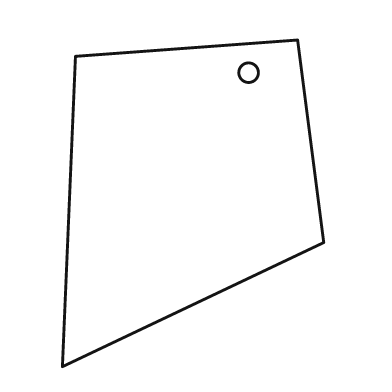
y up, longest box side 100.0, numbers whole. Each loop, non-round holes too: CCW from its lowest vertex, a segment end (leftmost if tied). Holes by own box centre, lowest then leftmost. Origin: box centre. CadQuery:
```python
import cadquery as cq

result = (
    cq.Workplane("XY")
    .moveTo(-40.0, -50.0)
    .lineTo(40.0, -12.0)
    .lineTo(32.0, 50.0)
    .lineTo(-36.0, 45.0)
    .close()
    .moveTo(17.0, 40.0)
    .circle(3.0)
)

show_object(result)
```